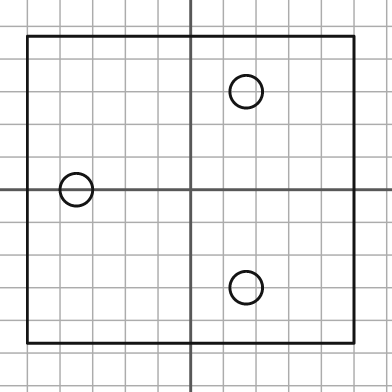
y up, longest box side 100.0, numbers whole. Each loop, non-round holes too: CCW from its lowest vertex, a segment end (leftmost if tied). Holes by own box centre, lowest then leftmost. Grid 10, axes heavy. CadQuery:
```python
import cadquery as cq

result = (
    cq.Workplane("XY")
    .moveTo(-50.0, -47.0)
    .lineTo(50.0, -47.0)
    .lineTo(50.0, 47.0)
    .lineTo(-50.0, 47.0)
    .close()
    .moveTo(17.0, -30.0)
    .circle(5.0)
    .moveTo(-35.0, 0.0)
    .circle(5.0)
    .moveTo(17.0, 30.0)
    .circle(5.0)
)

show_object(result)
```